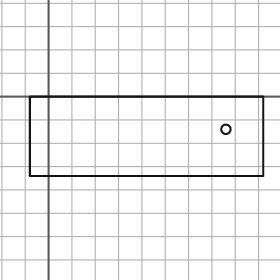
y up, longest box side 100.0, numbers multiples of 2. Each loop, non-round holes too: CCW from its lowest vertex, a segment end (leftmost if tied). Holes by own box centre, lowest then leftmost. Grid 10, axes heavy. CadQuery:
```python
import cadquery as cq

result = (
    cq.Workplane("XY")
    .moveTo(-8.0, -34.0)
    .lineTo(92.0, -34.0)
    .lineTo(92.0, 0.0)
    .lineTo(-8.0, 0.0)
    .close()
    .moveTo(76.0, -14.0)
    .circle(2.0)
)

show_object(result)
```